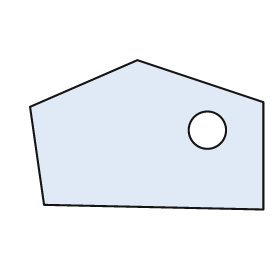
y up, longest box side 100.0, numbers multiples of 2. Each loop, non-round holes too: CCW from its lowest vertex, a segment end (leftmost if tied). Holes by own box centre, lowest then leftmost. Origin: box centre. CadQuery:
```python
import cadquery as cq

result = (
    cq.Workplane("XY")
    .moveTo(50.0, -32.0)
    .lineTo(50.0, 14.0)
    .lineTo(-4.0, 32.0)
    .lineTo(-50.0, 12.0)
    .lineTo(-44.0, -30.0)
    .close()
    .moveTo(26.0, 2.0)
    .circle(8.0)
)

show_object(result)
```